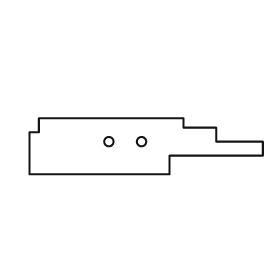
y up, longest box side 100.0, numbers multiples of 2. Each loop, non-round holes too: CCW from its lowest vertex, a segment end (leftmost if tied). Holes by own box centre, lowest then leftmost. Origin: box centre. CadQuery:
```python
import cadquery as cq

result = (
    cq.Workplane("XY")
    .moveTo(-50.0, -12.0)
    .lineTo(10.0, -12.0)
    .lineTo(10.0, -4.0)
    .lineTo(50.0, -4.0)
    .lineTo(50.0, 2.0)
    .lineTo(30.0, 2.0)
    .lineTo(30.0, 8.0)
    .lineTo(16.0, 8.0)
    .lineTo(16.0, 12.0)
    .lineTo(-46.0, 12.0)
    .lineTo(-46.0, 6.0)
    .lineTo(-50.0, 6.0)
    .close()
    .moveTo(-16.0, 2.0)
    .circle(2.0)
    .moveTo(-2.0, 2.0)
    .circle(2.0)
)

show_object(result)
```